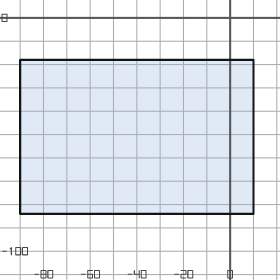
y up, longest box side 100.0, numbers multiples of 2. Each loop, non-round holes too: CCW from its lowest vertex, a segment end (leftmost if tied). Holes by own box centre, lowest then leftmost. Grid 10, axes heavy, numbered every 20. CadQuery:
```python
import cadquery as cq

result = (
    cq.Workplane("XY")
    .moveTo(-90.0, -84.0)
    .lineTo(10.0, -84.0)
    .lineTo(10.0, -18.0)
    .lineTo(-90.0, -18.0)
    .close()
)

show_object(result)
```